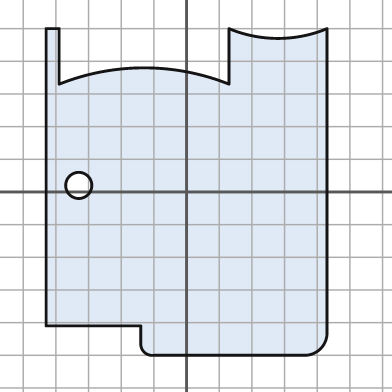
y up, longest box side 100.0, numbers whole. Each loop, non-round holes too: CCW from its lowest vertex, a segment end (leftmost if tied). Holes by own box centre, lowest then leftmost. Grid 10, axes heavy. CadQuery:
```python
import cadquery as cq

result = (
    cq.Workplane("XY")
    .moveTo(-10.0, -50.0)
    .lineTo(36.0, -50.0)
    .threePointArc((41.0, -48.0), (43.0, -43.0))
    .lineTo(43.0, 50.0)
    .threePointArc((28.0, 47.0), (13.0, 50.0))
    .lineTo(13.0, 33.0)
    .threePointArc((-13.0, 38.0), (-39.0, 33.0))
    .lineTo(-39.0, 50.0)
    .lineTo(-43.0, 50.0)
    .lineTo(-43.0, -41.0)
    .lineTo(-14.0, -41.0)
    .lineTo(-14.0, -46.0)
    .threePointArc((-13.0, -49.0), (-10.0, -50.0))
    .close()
    .moveTo(-33.0, 2.0)
    .circle(4.0)
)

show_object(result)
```